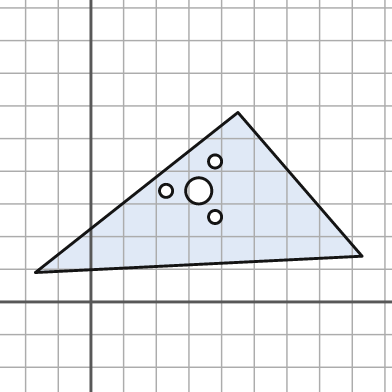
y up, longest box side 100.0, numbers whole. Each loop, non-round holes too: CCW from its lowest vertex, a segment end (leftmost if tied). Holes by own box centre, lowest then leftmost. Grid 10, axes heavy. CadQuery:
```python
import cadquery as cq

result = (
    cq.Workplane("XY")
    .moveTo(-17.0, 9.0)
    .lineTo(83.0, 14.0)
    .lineTo(45.0, 58.0)
    .close()
    .moveTo(38.0, 26.0)
    .circle(2.0)
    .moveTo(23.0, 34.0)
    .circle(2.0)
    .moveTo(33.0, 34.0)
    .circle(4.0)
    .moveTo(38.0, 43.0)
    .circle(2.0)
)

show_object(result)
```